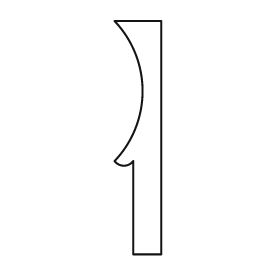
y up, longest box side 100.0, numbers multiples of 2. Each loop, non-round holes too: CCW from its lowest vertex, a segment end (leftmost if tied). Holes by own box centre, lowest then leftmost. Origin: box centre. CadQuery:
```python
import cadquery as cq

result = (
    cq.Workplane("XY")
    .moveTo(-2.0, -50.0)
    .lineTo(10.0, -50.0)
    .lineTo(10.0, 50.0)
    .lineTo(-10.0, 50.0)
    .threePointArc((2.0, 20.0), (-10.0, -10.0))
    .threePointArc((-6.0, -12.0), (-2.0, -10.0))
    .close()
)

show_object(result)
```